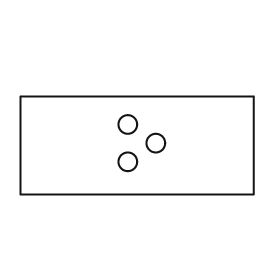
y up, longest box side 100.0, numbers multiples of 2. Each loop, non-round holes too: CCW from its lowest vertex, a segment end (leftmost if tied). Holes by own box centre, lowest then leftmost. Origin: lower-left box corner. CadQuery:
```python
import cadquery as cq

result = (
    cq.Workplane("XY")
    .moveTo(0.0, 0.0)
    .lineTo(100.0, 0.0)
    .lineTo(100.0, 42.0)
    .lineTo(0.0, 42.0)
    .close()
    .moveTo(46.0, 14.0)
    .circle(4.0)
    .moveTo(58.0, 22.0)
    .circle(4.0)
    .moveTo(46.0, 30.0)
    .circle(4.0)
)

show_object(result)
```